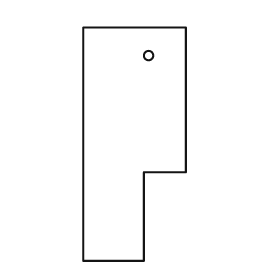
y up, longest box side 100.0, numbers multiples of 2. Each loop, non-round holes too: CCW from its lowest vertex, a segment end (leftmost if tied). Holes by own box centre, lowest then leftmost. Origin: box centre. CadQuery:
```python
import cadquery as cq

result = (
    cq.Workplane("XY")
    .moveTo(-22.0, -50.0)
    .lineTo(4.0, -50.0)
    .lineTo(4.0, -12.0)
    .lineTo(22.0, -12.0)
    .lineTo(22.0, 50.0)
    .lineTo(-22.0, 50.0)
    .close()
    .moveTo(6.0, 38.0)
    .circle(2.0)
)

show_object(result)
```